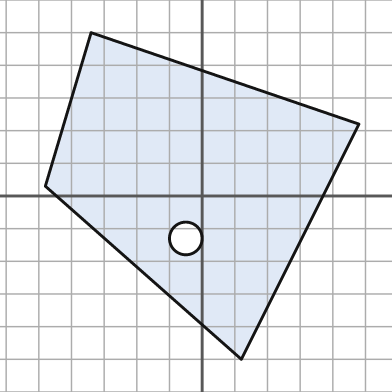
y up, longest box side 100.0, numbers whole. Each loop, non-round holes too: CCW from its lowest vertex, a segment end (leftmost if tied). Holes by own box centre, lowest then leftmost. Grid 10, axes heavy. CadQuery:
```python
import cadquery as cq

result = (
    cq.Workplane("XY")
    .moveTo(12.0, -50.0)
    .lineTo(48.0, 22.0)
    .lineTo(-34.0, 50.0)
    .lineTo(-48.0, 3.0)
    .close()
    .moveTo(-5.0, -13.0)
    .circle(5.0)
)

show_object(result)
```